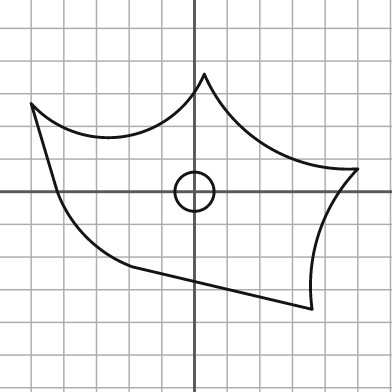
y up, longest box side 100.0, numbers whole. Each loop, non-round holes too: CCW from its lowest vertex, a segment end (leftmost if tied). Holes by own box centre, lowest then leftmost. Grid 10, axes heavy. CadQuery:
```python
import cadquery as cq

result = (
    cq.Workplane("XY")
    .moveTo(36.0, -36.0)
    .threePointArc((38.0, -13.0), (50.0, 7.0))
    .threePointArc((22.0, 14.0), (3.0, 36.0))
    .threePointArc((-21.0, 17.0), (-50.0, 27.0))
    .lineTo(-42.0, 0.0)
    .threePointArc((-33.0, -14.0), (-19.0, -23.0))
    .close()
    .moveTo(0.0, 0.0)
    .circle(6.0)
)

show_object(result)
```